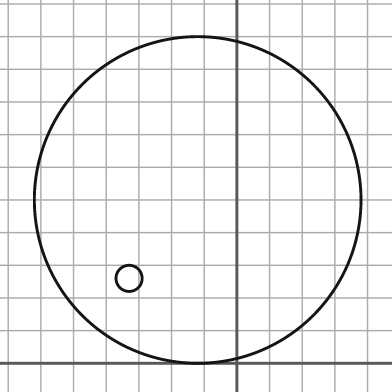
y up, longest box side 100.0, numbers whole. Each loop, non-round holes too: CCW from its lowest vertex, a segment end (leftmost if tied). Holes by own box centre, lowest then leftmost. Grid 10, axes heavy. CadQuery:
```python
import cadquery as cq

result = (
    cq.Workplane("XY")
    .moveTo(-12.0, 50.0)
    .circle(50.0)
    .moveTo(-33.0, 26.0)
    .circle(4.0)
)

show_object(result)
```